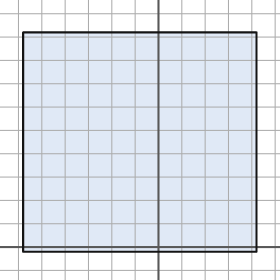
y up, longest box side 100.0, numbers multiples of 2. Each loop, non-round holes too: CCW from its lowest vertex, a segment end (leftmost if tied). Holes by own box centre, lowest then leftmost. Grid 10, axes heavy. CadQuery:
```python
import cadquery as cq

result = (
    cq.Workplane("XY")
    .moveTo(-58.0, -2.0)
    .lineTo(42.0, -2.0)
    .lineTo(42.0, 92.0)
    .lineTo(-58.0, 92.0)
    .close()
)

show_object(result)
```